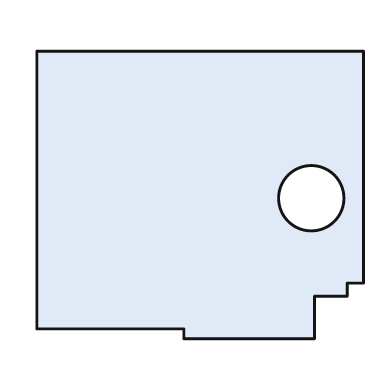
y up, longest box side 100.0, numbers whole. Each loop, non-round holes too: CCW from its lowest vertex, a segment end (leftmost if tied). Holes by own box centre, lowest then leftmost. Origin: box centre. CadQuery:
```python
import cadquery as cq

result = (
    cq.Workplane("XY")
    .moveTo(-5.0, -44.0)
    .lineTo(35.0, -44.0)
    .lineTo(35.0, -31.0)
    .lineTo(45.0, -31.0)
    .lineTo(45.0, -27.0)
    .lineTo(50.0, -27.0)
    .lineTo(50.0, 44.0)
    .lineTo(-50.0, 44.0)
    .lineTo(-50.0, -41.0)
    .lineTo(-5.0, -41.0)
    .close()
    .moveTo(34.0, -1.0)
    .circle(10.0)
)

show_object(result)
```